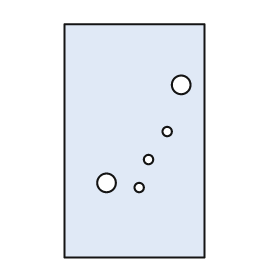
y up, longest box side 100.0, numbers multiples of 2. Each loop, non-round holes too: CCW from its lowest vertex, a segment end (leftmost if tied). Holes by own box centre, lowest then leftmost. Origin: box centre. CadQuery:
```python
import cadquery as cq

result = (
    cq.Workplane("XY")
    .moveTo(-30.0, -50.0)
    .lineTo(30.0, -50.0)
    .lineTo(30.0, 50.0)
    .lineTo(-30.0, 50.0)
    .close()
    .moveTo(2.0, -20.0)
    .circle(2.0)
    .moveTo(-12.0, -18.0)
    .circle(4.0)
    .moveTo(6.0, -8.0)
    .circle(2.0)
    .moveTo(14.0, 4.0)
    .circle(2.0)
    .moveTo(20.0, 24.0)
    .circle(4.0)
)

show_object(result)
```